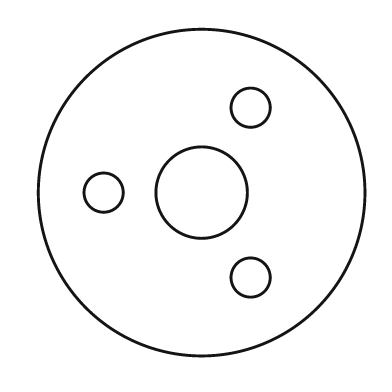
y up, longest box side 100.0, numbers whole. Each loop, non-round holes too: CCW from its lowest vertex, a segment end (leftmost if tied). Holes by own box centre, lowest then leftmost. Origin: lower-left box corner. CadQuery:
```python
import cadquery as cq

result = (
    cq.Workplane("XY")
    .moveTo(50.0, 50.0)
    .circle(50.0)
    .moveTo(65.0, 24.0)
    .circle(6.0)
    .moveTo(20.0, 50.0)
    .circle(6.0)
    .moveTo(50.0, 50.0)
    .circle(14.0)
    .moveTo(65.0, 76.0)
    .circle(6.0)
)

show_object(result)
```